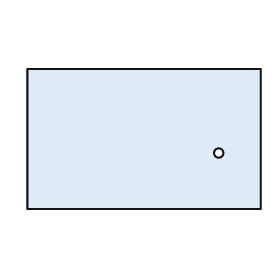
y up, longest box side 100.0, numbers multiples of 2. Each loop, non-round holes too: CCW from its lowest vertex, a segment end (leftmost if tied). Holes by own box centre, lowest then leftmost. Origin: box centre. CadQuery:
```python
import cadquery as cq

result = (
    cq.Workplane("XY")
    .moveTo(-50.0, -30.0)
    .lineTo(50.0, -30.0)
    .lineTo(50.0, 30.0)
    .lineTo(-50.0, 30.0)
    .close()
    .moveTo(32.0, -6.0)
    .circle(2.0)
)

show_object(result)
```